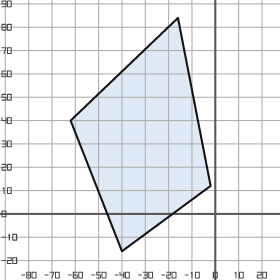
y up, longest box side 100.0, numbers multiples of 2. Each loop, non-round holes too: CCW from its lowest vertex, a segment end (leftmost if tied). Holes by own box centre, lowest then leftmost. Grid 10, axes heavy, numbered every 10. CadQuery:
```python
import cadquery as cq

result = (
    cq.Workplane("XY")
    .moveTo(-40.0, -16.0)
    .lineTo(-2.0, 12.0)
    .lineTo(-16.0, 84.0)
    .lineTo(-62.0, 40.0)
    .close()
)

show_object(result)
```